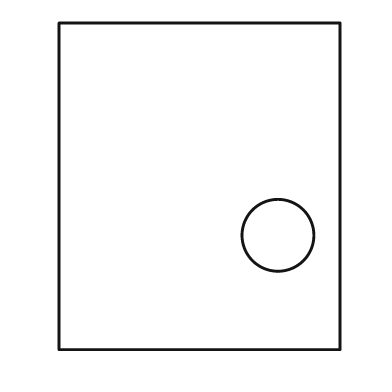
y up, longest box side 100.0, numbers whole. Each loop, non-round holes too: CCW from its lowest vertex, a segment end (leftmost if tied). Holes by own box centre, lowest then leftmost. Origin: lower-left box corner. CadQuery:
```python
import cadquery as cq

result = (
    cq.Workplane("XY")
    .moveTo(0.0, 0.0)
    .lineTo(86.0, 0.0)
    .lineTo(86.0, 100.0)
    .lineTo(0.0, 100.0)
    .close()
    .moveTo(67.0, 35.0)
    .circle(11.0)
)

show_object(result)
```